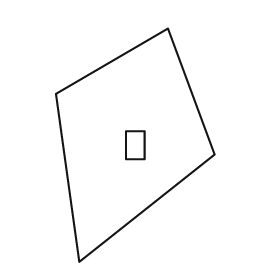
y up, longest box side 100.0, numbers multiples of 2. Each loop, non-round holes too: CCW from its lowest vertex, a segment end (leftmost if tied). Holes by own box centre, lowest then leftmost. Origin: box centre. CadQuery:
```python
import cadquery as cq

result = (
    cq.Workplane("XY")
    .moveTo(-24.0, -50.0)
    .lineTo(34.0, -4.0)
    .lineTo(14.0, 50.0)
    .lineTo(-34.0, 22.0)
    .close()
    .moveTo(-4.0, -6.0)
    .lineTo(4.0, -6.0)
    .lineTo(4.0, 6.0)
    .lineTo(-4.0, 6.0)
    .close()
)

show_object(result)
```